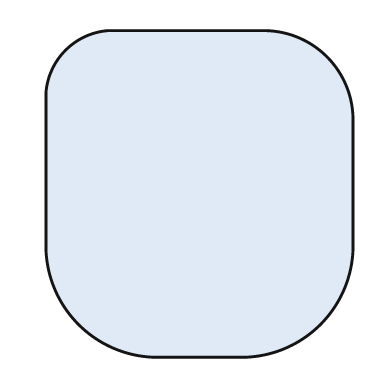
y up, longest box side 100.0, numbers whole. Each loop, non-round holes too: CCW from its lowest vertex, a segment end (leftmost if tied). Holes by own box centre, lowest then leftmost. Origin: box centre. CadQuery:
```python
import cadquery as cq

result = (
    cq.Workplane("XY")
    .moveTo(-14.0, -50.0)
    .lineTo(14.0, -50.0)
    .threePointArc((37.0, -40.0), (47.0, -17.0))
    .lineTo(47.0, 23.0)
    .threePointArc((39.0, 42.0), (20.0, 50.0))
    .lineTo(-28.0, 50.0)
    .threePointArc((-41.0, 44.0), (-47.0, 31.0))
    .lineTo(-47.0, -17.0)
    .threePointArc((-37.0, -40.0), (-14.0, -50.0))
    .close()
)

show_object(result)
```